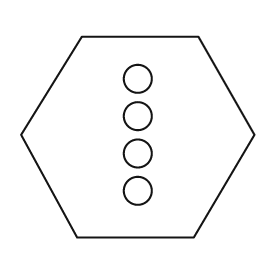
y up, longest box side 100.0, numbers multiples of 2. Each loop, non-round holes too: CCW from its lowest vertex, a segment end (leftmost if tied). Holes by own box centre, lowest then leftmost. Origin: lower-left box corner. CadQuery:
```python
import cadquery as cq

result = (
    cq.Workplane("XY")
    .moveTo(24.0, 0.0)
    .lineTo(74.0, 0.0)
    .lineTo(100.0, 44.0)
    .lineTo(76.0, 86.0)
    .lineTo(26.0, 86.0)
    .lineTo(0.0, 44.0)
    .close()
    .moveTo(50.0, 20.0)
    .circle(6.0)
    .moveTo(50.0, 36.0)
    .circle(6.0)
    .moveTo(50.0, 52.0)
    .circle(6.0)
    .moveTo(50.0, 68.0)
    .circle(6.0)
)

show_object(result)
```